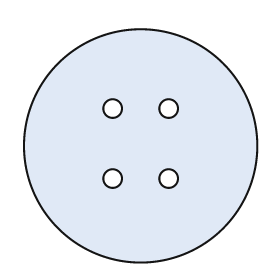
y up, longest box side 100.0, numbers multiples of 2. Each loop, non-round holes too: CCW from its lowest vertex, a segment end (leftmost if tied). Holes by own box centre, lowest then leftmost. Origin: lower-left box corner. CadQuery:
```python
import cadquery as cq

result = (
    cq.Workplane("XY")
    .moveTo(50.0, 50.0)
    .circle(50.0)
    .moveTo(38.0, 36.0)
    .circle(4.0)
    .moveTo(62.0, 36.0)
    .circle(4.0)
    .moveTo(38.0, 66.0)
    .circle(4.0)
    .moveTo(62.0, 66.0)
    .circle(4.0)
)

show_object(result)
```